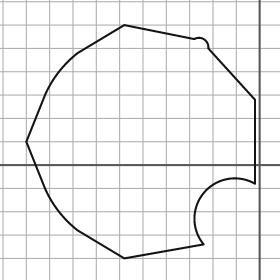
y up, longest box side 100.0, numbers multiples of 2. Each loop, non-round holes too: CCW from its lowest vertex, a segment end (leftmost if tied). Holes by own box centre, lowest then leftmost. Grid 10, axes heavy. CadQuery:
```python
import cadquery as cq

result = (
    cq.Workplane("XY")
    .moveTo(-58.0, -40.0)
    .lineTo(-24.0, -34.0)
    .threePointArc((-24.0, -12.0), (-2.0, -8.0))
    .lineTo(-2.0, 28.0)
    .lineTo(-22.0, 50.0)
    .threePointArc((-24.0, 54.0), (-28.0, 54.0))
    .lineTo(-58.0, 60.0)
    .lineTo(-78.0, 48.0)
    .threePointArc((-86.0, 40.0), (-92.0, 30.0))
    .lineTo(-100.0, 10.0)
    .lineTo(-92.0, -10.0)
    .threePointArc((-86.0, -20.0), (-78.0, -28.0))
    .close()
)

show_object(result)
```